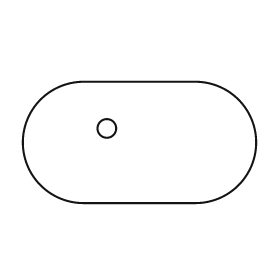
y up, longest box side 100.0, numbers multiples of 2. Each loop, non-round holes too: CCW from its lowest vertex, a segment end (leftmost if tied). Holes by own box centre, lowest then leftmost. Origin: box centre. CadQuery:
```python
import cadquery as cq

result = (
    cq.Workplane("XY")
    .moveTo(-24.0, -26.0)
    .lineTo(24.0, -26.0)
    .threePointArc((50.0, 0.0), (24.0, 26.0))
    .lineTo(-24.0, 26.0)
    .threePointArc((-50.0, 0.0), (-24.0, -26.0))
    .close()
    .moveTo(-14.0, 6.0)
    .circle(4.0)
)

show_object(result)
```